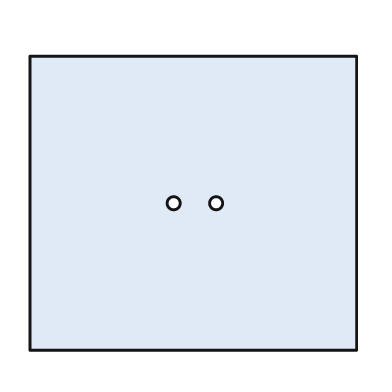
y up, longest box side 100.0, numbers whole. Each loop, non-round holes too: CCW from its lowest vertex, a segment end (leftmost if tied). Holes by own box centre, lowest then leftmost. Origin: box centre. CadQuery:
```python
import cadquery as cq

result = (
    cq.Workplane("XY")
    .moveTo(-50.0, -45.0)
    .lineTo(50.0, -45.0)
    .lineTo(50.0, 45.0)
    .lineTo(-50.0, 45.0)
    .close()
    .moveTo(-6.0, 0.0)
    .circle(2.0)
    .moveTo(7.0, 0.0)
    .circle(2.0)
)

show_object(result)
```